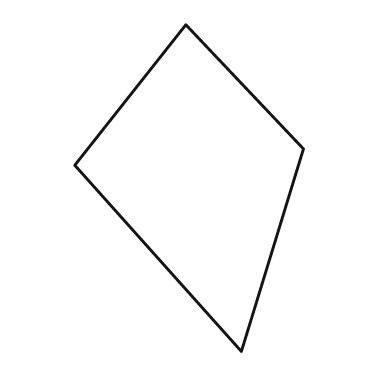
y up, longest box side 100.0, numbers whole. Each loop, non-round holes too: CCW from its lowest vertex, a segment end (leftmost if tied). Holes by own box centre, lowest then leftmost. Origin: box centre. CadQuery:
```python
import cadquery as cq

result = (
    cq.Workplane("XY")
    .moveTo(16.0, -50.0)
    .lineTo(35.0, 12.0)
    .lineTo(-1.0, 50.0)
    .lineTo(-35.0, 7.0)
    .close()
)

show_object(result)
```